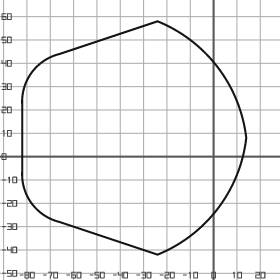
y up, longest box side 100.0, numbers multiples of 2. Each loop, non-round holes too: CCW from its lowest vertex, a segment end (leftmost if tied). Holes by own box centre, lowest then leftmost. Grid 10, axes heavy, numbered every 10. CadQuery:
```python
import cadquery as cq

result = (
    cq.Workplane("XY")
    .moveTo(-24.0, -42.0)
    .threePointArc((2.0, -22.0), (14.0, 8.0))
    .threePointArc((2.0, 38.0), (-24.0, 58.0))
    .lineTo(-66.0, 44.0)
    .threePointArc((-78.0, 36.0), (-82.0, 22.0))
    .lineTo(-82.0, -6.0)
    .threePointArc((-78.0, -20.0), (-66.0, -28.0))
    .close()
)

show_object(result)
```